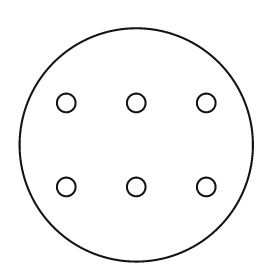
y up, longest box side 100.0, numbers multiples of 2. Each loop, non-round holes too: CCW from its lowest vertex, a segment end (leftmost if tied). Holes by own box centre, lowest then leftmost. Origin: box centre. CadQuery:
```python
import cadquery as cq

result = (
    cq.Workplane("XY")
    .moveTo(0.0, 0.0)
    .circle(50.0)
    .moveTo(-30.0, -18.0)
    .circle(4.0)
    .moveTo(0.0, -18.0)
    .circle(4.0)
    .moveTo(30.0, -18.0)
    .circle(4.0)
    .moveTo(-30.0, 18.0)
    .circle(4.0)
    .moveTo(0.0, 18.0)
    .circle(4.0)
    .moveTo(30.0, 18.0)
    .circle(4.0)
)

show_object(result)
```